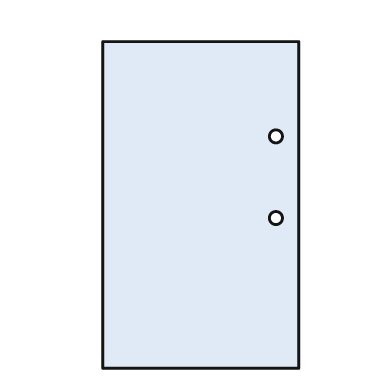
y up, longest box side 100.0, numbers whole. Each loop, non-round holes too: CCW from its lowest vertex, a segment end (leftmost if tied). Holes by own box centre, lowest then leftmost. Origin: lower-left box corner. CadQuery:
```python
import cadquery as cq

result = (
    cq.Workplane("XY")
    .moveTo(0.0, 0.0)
    .lineTo(60.0, 0.0)
    .lineTo(60.0, 100.0)
    .lineTo(0.0, 100.0)
    .close()
    .moveTo(53.0, 46.0)
    .circle(2.0)
    .moveTo(53.0, 71.0)
    .circle(2.0)
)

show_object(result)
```